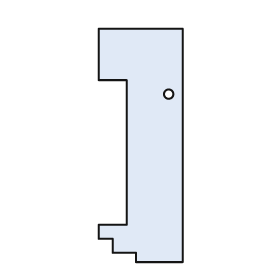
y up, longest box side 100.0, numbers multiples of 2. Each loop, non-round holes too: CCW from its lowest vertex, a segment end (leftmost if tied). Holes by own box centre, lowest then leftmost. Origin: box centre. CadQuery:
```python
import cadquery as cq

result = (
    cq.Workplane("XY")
    .moveTo(-2.0, -50.0)
    .lineTo(18.0, -50.0)
    .lineTo(18.0, 50.0)
    .lineTo(-18.0, 50.0)
    .lineTo(-18.0, 28.0)
    .lineTo(-6.0, 28.0)
    .lineTo(-6.0, -34.0)
    .lineTo(-18.0, -34.0)
    .lineTo(-18.0, -40.0)
    .lineTo(-12.0, -40.0)
    .lineTo(-12.0, -46.0)
    .lineTo(-2.0, -46.0)
    .close()
    .moveTo(12.0, 22.0)
    .circle(2.0)
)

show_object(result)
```